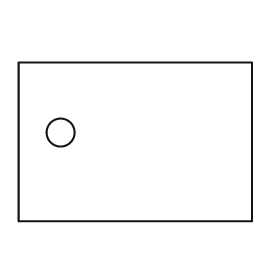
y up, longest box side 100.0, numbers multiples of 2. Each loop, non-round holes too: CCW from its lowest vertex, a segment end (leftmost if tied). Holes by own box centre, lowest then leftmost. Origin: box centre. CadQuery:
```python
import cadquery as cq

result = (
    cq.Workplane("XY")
    .moveTo(-50.0, -34.0)
    .lineTo(50.0, -34.0)
    .lineTo(50.0, 34.0)
    .lineTo(-50.0, 34.0)
    .close()
    .moveTo(-32.0, 4.0)
    .circle(6.0)
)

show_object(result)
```